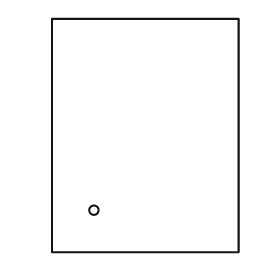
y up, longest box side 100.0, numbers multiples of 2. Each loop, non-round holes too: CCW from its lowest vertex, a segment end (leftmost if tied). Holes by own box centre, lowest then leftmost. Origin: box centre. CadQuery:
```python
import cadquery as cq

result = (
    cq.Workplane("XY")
    .moveTo(-40.0, -50.0)
    .lineTo(40.0, -50.0)
    .lineTo(40.0, 50.0)
    .lineTo(-40.0, 50.0)
    .close()
    .moveTo(-22.0, -32.0)
    .circle(2.0)
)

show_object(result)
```